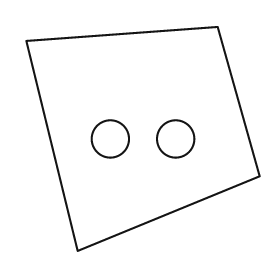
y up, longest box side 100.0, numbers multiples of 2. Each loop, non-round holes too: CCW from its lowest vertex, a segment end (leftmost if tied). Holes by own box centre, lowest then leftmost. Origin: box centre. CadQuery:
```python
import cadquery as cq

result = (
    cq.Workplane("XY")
    .moveTo(-28.0, -48.0)
    .lineTo(50.0, -16.0)
    .lineTo(32.0, 48.0)
    .lineTo(-50.0, 42.0)
    .close()
    .moveTo(-14.0, 0.0)
    .circle(8.0)
    .moveTo(14.0, 0.0)
    .circle(8.0)
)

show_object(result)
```